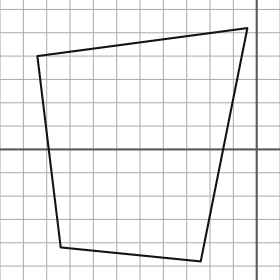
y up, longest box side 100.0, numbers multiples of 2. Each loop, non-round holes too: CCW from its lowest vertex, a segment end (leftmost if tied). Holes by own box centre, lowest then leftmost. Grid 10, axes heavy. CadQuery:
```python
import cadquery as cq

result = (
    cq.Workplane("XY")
    .moveTo(-24.0, -48.0)
    .lineTo(-4.0, 52.0)
    .lineTo(-94.0, 40.0)
    .lineTo(-84.0, -42.0)
    .close()
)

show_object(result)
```